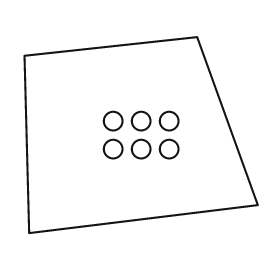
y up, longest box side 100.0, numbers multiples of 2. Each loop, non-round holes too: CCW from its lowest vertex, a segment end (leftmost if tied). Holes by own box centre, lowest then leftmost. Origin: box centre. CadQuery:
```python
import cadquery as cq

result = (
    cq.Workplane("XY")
    .moveTo(-48.0, -42.0)
    .lineTo(50.0, -30.0)
    .lineTo(24.0, 42.0)
    .lineTo(-50.0, 34.0)
    .close()
    .moveTo(-12.0, -6.0)
    .circle(4.0)
    .moveTo(0.0, -6.0)
    .circle(4.0)
    .moveTo(12.0, -6.0)
    .circle(4.0)
    .moveTo(-12.0, 6.0)
    .circle(4.0)
    .moveTo(0.0, 6.0)
    .circle(4.0)
    .moveTo(12.0, 6.0)
    .circle(4.0)
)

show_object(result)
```